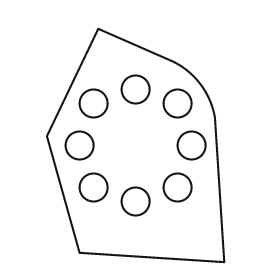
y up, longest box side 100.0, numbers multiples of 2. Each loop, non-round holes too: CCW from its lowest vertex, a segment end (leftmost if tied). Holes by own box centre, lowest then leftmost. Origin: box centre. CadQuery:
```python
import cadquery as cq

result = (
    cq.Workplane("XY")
    .moveTo(38.0, -50.0)
    .lineTo(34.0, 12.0)
    .threePointArc((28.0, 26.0), (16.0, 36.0))
    .lineTo(-16.0, 50.0)
    .lineTo(-38.0, 4.0)
    .lineTo(-24.0, -46.0)
    .close()
    .moveTo(0.0, -24.0)
    .circle(6.0)
    .moveTo(-18.0, -18.0)
    .circle(6.0)
    .moveTo(18.0, -18.0)
    .circle(6.0)
    .moveTo(-24.0, 0.0)
    .circle(6.0)
    .moveTo(24.0, 0.0)
    .circle(6.0)
    .moveTo(-18.0, 18.0)
    .circle(6.0)
    .moveTo(18.0, 18.0)
    .circle(6.0)
    .moveTo(0.0, 24.0)
    .circle(6.0)
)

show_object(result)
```